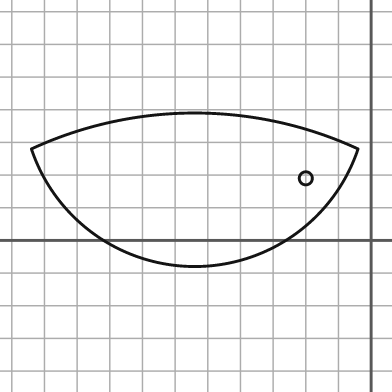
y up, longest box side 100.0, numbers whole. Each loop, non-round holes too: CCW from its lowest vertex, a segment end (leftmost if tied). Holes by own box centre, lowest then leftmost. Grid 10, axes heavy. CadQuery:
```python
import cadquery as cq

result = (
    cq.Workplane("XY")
    .moveTo(-104.0, 28.0)
    .threePointArc((-54.0, -8.0), (-4.0, 28.0))
    .threePointArc((-54.0, 39.0), (-104.0, 28.0))
    .close()
    .moveTo(-20.0, 19.0)
    .circle(2.0)
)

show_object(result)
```